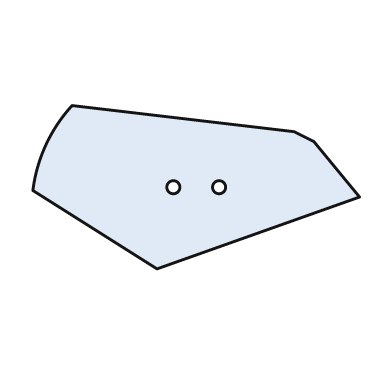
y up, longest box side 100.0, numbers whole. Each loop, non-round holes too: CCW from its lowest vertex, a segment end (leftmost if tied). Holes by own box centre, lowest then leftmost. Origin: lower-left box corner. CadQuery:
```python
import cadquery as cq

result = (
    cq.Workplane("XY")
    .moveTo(38.0, 0.0)
    .lineTo(100.0, 22.0)
    .lineTo(86.0, 39.0)
    .lineTo(80.0, 42.0)
    .lineTo(12.0, 50.0)
    .threePointArc((4.0, 38.0), (0.0, 24.0))
    .close()
    .moveTo(43.0, 25.0)
    .circle(2.0)
    .moveTo(57.0, 25.0)
    .circle(2.0)
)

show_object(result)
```